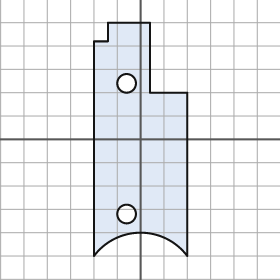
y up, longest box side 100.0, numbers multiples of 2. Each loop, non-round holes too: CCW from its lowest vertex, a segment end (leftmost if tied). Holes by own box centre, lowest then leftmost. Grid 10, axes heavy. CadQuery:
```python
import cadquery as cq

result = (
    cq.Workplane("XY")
    .moveTo(-20.0, -50.0)
    .threePointArc((0.0, -40.0), (20.0, -50.0))
    .lineTo(20.0, 20.0)
    .lineTo(4.0, 20.0)
    .lineTo(4.0, 50.0)
    .lineTo(-14.0, 50.0)
    .lineTo(-14.0, 42.0)
    .lineTo(-20.0, 42.0)
    .close()
    .moveTo(-6.0, -32.0)
    .circle(4.0)
    .moveTo(-6.0, 24.0)
    .circle(4.0)
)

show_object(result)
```